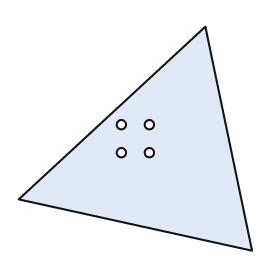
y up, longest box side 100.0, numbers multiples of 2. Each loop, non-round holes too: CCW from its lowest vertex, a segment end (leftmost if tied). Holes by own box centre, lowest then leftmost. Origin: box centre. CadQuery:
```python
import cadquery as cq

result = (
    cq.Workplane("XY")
    .moveTo(50.0, -48.0)
    .lineTo(30.0, 48.0)
    .lineTo(-50.0, -26.0)
    .close()
    .moveTo(-6.0, -6.0)
    .circle(2.0)
    .moveTo(6.0, -6.0)
    .circle(2.0)
    .moveTo(-6.0, 6.0)
    .circle(2.0)
    .moveTo(6.0, 6.0)
    .circle(2.0)
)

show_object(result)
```